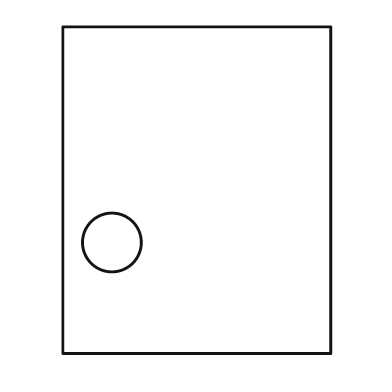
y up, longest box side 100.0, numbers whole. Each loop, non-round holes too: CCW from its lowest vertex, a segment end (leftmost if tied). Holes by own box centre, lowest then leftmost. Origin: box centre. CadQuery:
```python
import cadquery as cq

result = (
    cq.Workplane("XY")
    .moveTo(-41.0, -50.0)
    .lineTo(41.0, -50.0)
    .lineTo(41.0, 50.0)
    .lineTo(-41.0, 50.0)
    .close()
    .moveTo(-26.0, -16.0)
    .circle(9.0)
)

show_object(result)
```